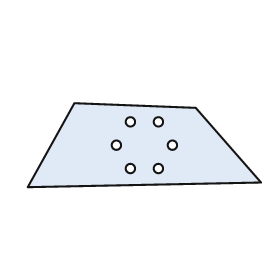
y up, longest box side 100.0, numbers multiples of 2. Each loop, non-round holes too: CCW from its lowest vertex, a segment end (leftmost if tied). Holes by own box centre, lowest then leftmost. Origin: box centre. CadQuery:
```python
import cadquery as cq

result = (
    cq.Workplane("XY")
    .moveTo(-50.0, -18.0)
    .lineTo(50.0, -16.0)
    .lineTo(22.0, 16.0)
    .lineTo(-30.0, 18.0)
    .close()
    .moveTo(-6.0, -10.0)
    .circle(2.0)
    .moveTo(6.0, -10.0)
    .circle(2.0)
    .moveTo(-12.0, 0.0)
    .circle(2.0)
    .moveTo(12.0, 0.0)
    .circle(2.0)
    .moveTo(-6.0, 10.0)
    .circle(2.0)
    .moveTo(6.0, 10.0)
    .circle(2.0)
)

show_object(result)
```